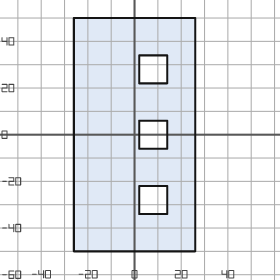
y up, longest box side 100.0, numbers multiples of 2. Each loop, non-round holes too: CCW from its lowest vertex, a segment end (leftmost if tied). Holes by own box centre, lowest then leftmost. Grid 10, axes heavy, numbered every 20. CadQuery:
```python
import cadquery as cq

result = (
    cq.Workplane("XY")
    .moveTo(-26.0, -50.0)
    .lineTo(26.0, -50.0)
    .lineTo(26.0, 50.0)
    .lineTo(-26.0, 50.0)
    .close()
    .moveTo(2.0, -34.0)
    .lineTo(14.0, -34.0)
    .lineTo(14.0, -22.0)
    .lineTo(2.0, -22.0)
    .close()
    .moveTo(2.0, -6.0)
    .lineTo(14.0, -6.0)
    .lineTo(14.0, 6.0)
    .lineTo(2.0, 6.0)
    .close()
    .moveTo(2.0, 22.0)
    .lineTo(14.0, 22.0)
    .lineTo(14.0, 34.0)
    .lineTo(2.0, 34.0)
    .close()
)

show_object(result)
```